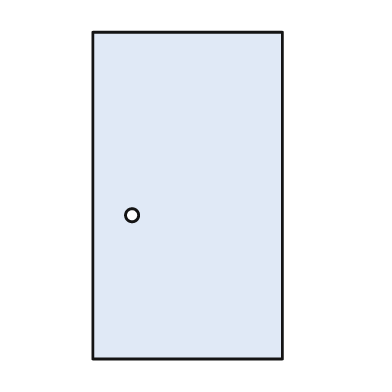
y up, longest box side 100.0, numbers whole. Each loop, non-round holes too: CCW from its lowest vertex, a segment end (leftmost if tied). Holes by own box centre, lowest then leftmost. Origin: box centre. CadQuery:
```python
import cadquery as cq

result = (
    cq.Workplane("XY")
    .moveTo(-29.0, -50.0)
    .lineTo(29.0, -50.0)
    .lineTo(29.0, 50.0)
    .lineTo(-29.0, 50.0)
    .close()
    .moveTo(-17.0, -6.0)
    .circle(2.0)
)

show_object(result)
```